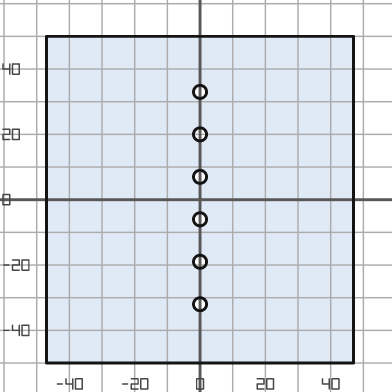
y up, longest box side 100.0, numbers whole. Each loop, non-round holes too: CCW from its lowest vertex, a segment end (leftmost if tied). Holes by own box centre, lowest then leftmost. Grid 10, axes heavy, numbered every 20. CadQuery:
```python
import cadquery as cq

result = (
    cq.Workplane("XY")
    .moveTo(-47.0, -50.0)
    .lineTo(47.0, -50.0)
    .lineTo(47.0, 50.0)
    .lineTo(-47.0, 50.0)
    .close()
    .moveTo(0.0, -32.0)
    .circle(2.0)
    .moveTo(0.0, -19.0)
    .circle(2.0)
    .moveTo(0.0, -6.0)
    .circle(2.0)
    .moveTo(0.0, 7.0)
    .circle(2.0)
    .moveTo(0.0, 20.0)
    .circle(2.0)
    .moveTo(0.0, 33.0)
    .circle(2.0)
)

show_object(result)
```